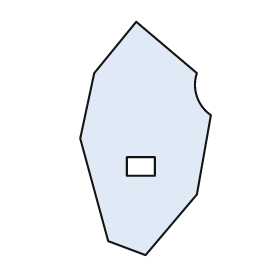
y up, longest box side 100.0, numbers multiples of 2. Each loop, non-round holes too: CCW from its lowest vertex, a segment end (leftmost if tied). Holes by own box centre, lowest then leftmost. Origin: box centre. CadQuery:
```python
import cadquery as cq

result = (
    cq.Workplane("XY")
    .moveTo(0.0, -50.0)
    .lineTo(22.0, -24.0)
    .lineTo(28.0, 10.0)
    .threePointArc((22.0, 18.0), (22.0, 28.0))
    .lineTo(-4.0, 50.0)
    .lineTo(-22.0, 28.0)
    .lineTo(-28.0, 0.0)
    .lineTo(-16.0, -44.0)
    .close()
    .moveTo(-8.0, -16.0)
    .lineTo(4.0, -16.0)
    .lineTo(4.0, -8.0)
    .lineTo(-8.0, -8.0)
    .close()
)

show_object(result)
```